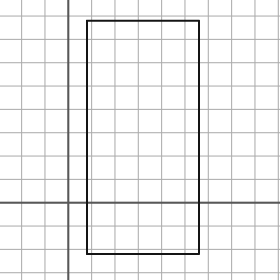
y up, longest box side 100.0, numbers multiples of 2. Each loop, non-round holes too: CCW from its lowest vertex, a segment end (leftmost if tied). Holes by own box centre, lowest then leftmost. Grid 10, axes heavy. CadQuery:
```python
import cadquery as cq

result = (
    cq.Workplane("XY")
    .moveTo(8.0, -22.0)
    .lineTo(56.0, -22.0)
    .lineTo(56.0, 78.0)
    .lineTo(8.0, 78.0)
    .close()
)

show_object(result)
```